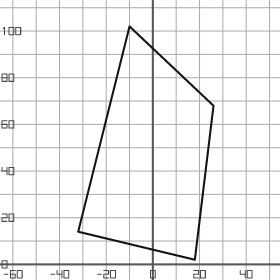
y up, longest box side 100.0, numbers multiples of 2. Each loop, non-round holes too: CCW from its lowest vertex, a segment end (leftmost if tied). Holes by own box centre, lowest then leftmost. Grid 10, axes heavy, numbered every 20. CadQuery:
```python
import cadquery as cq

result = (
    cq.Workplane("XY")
    .moveTo(18.0, 2.0)
    .lineTo(26.0, 68.0)
    .lineTo(-10.0, 102.0)
    .lineTo(-32.0, 14.0)
    .close()
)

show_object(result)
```